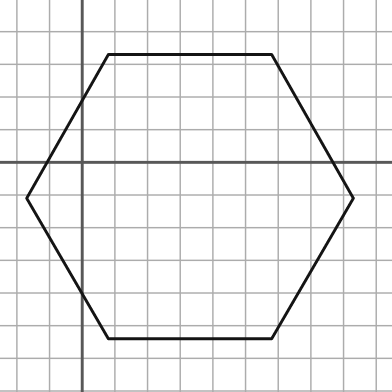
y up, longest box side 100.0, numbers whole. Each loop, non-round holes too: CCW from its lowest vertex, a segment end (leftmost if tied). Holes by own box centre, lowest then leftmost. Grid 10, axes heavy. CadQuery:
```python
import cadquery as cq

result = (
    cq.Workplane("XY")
    .moveTo(8.0, -54.0)
    .lineTo(58.0, -54.0)
    .lineTo(83.0, -11.0)
    .lineTo(58.0, 33.0)
    .lineTo(8.0, 33.0)
    .lineTo(-17.0, -11.0)
    .close()
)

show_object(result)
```